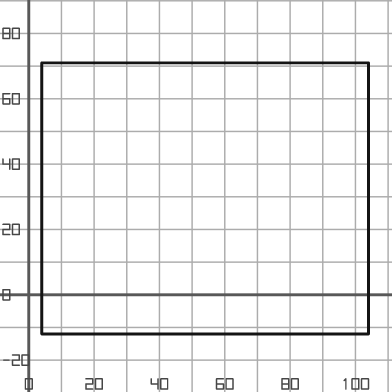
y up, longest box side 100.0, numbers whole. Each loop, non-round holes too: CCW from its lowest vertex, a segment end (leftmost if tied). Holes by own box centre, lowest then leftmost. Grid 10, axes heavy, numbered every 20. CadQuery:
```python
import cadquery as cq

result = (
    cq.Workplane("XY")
    .moveTo(4.0, -12.0)
    .lineTo(104.0, -12.0)
    .lineTo(104.0, 71.0)
    .lineTo(4.0, 71.0)
    .close()
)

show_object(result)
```